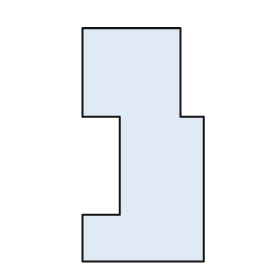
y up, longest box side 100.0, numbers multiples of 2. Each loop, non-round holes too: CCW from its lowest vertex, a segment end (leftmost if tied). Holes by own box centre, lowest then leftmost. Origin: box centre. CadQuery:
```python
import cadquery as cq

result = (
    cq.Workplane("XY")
    .moveTo(-26.0, -50.0)
    .lineTo(26.0, -50.0)
    .lineTo(26.0, 12.0)
    .lineTo(16.0, 12.0)
    .lineTo(16.0, 50.0)
    .lineTo(-26.0, 50.0)
    .lineTo(-26.0, 12.0)
    .lineTo(-10.0, 12.0)
    .lineTo(-10.0, -30.0)
    .lineTo(-26.0, -30.0)
    .close()
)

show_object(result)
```